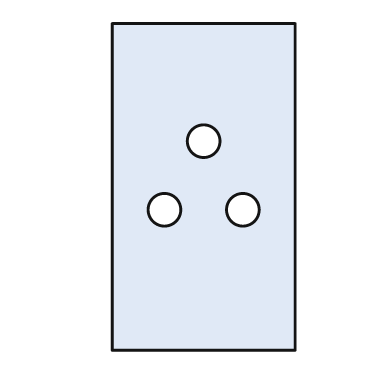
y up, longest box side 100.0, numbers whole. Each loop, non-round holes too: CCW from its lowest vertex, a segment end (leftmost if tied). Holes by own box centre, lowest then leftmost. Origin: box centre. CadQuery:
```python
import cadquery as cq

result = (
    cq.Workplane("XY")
    .moveTo(-28.0, -50.0)
    .lineTo(28.0, -50.0)
    .lineTo(28.0, 50.0)
    .lineTo(-28.0, 50.0)
    .close()
    .moveTo(-12.0, -7.0)
    .circle(5.0)
    .moveTo(12.0, -7.0)
    .circle(5.0)
    .moveTo(0.0, 14.0)
    .circle(5.0)
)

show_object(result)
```